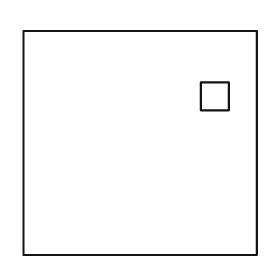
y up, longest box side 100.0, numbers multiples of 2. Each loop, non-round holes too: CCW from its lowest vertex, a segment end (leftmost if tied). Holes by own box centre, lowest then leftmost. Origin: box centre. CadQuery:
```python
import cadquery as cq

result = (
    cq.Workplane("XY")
    .moveTo(-50.0, -48.0)
    .lineTo(50.0, -48.0)
    .lineTo(50.0, 48.0)
    .lineTo(-50.0, 48.0)
    .close()
    .moveTo(26.0, 14.0)
    .lineTo(38.0, 14.0)
    .lineTo(38.0, 26.0)
    .lineTo(26.0, 26.0)
    .close()
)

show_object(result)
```